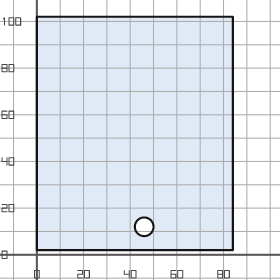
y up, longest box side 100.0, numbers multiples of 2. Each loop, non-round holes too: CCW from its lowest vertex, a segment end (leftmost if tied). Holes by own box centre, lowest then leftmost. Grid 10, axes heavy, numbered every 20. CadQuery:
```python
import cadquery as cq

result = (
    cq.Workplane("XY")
    .moveTo(0.0, 2.0)
    .lineTo(84.0, 2.0)
    .lineTo(84.0, 102.0)
    .lineTo(0.0, 102.0)
    .close()
    .moveTo(46.0, 12.0)
    .circle(4.0)
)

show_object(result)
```